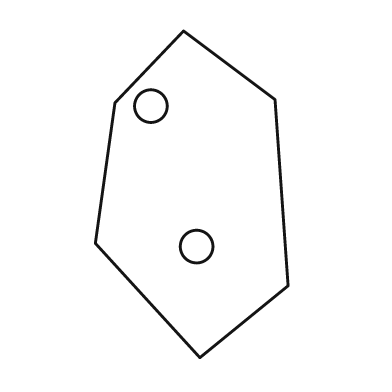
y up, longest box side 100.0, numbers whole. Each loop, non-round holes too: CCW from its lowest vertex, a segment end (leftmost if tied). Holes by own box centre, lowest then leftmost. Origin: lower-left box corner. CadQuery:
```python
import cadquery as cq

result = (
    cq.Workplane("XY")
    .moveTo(32.0, 0.0)
    .lineTo(59.0, 22.0)
    .lineTo(55.0, 79.0)
    .lineTo(27.0, 100.0)
    .lineTo(6.0, 78.0)
    .lineTo(0.0, 35.0)
    .close()
    .moveTo(31.0, 34.0)
    .circle(5.0)
    .moveTo(17.0, 77.0)
    .circle(5.0)
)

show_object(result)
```